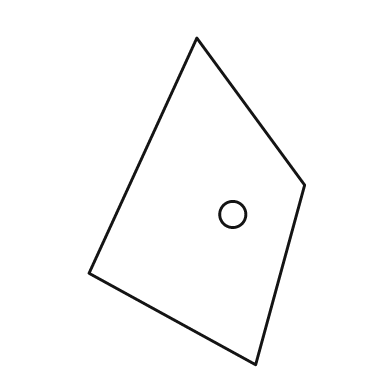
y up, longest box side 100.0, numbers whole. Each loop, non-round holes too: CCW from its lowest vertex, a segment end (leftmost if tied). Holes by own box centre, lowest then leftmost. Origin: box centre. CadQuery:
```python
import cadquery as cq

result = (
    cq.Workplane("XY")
    .moveTo(18.0, -50.0)
    .lineTo(33.0, 5.0)
    .lineTo(0.0, 50.0)
    .lineTo(-33.0, -22.0)
    .close()
    .moveTo(11.0, -4.0)
    .circle(4.0)
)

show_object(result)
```